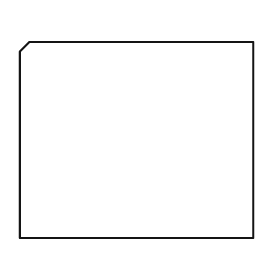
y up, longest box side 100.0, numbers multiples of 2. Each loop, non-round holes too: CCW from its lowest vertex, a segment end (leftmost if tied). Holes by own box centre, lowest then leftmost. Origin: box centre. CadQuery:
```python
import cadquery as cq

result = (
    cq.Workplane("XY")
    .moveTo(-50.0, -42.0)
    .lineTo(50.0, -42.0)
    .lineTo(50.0, 42.0)
    .lineTo(-46.0, 42.0)
    .lineTo(-50.0, 38.0)
    .close()
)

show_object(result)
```